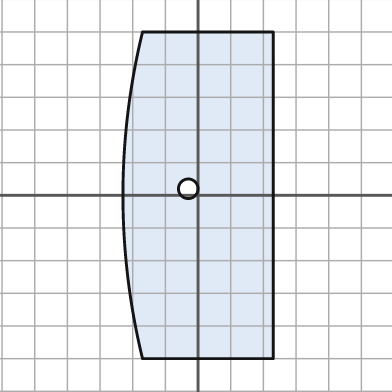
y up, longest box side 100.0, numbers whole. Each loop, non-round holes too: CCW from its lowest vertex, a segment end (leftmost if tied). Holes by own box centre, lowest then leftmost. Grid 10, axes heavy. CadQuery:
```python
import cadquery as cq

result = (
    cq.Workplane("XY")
    .moveTo(-17.0, -50.0)
    .lineTo(23.0, -50.0)
    .lineTo(23.0, 50.0)
    .lineTo(-17.0, 50.0)
    .threePointArc((-23.0, 0.0), (-17.0, -50.0))
    .close()
    .moveTo(-3.0, 2.0)
    .circle(3.0)
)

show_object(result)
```